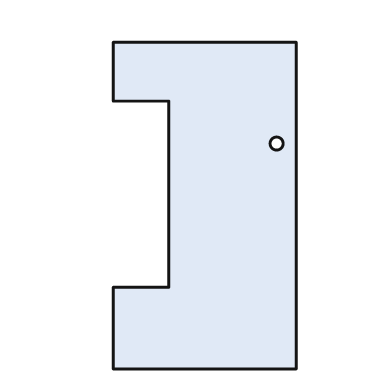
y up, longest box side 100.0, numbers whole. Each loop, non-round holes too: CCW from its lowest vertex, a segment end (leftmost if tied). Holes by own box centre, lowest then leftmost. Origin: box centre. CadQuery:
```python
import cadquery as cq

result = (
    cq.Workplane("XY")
    .moveTo(-28.0, -50.0)
    .lineTo(28.0, -50.0)
    .lineTo(28.0, 50.0)
    .lineTo(-28.0, 50.0)
    .lineTo(-28.0, 32.0)
    .lineTo(-11.0, 32.0)
    .lineTo(-11.0, -25.0)
    .lineTo(-28.0, -25.0)
    .close()
    .moveTo(22.0, 19.0)
    .circle(2.0)
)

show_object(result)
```